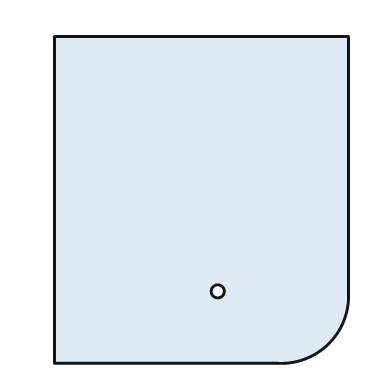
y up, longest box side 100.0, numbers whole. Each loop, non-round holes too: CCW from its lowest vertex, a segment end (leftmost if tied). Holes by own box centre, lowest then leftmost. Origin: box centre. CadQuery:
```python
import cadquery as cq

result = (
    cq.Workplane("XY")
    .moveTo(-45.0, -50.0)
    .lineTo(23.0, -50.0)
    .threePointArc((39.0, -44.0), (45.0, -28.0))
    .lineTo(45.0, 50.0)
    .lineTo(-45.0, 50.0)
    .close()
    .moveTo(5.0, -28.0)
    .circle(2.0)
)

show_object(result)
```